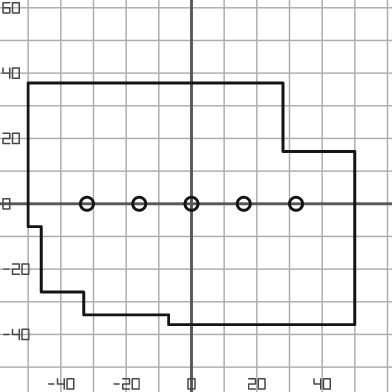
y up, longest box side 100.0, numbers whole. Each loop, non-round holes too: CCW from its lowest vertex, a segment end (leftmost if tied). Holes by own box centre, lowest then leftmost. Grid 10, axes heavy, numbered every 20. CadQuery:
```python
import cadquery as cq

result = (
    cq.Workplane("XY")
    .moveTo(-7.0, -37.0)
    .lineTo(50.0, -37.0)
    .lineTo(50.0, 16.0)
    .lineTo(28.0, 16.0)
    .lineTo(28.0, 37.0)
    .lineTo(-50.0, 37.0)
    .lineTo(-50.0, -7.0)
    .lineTo(-46.0, -7.0)
    .lineTo(-46.0, -27.0)
    .lineTo(-33.0, -27.0)
    .lineTo(-33.0, -34.0)
    .lineTo(-7.0, -34.0)
    .close()
    .moveTo(-32.0, 0.0)
    .circle(2.0)
    .moveTo(-16.0, 0.0)
    .circle(2.0)
    .moveTo(0.0, 0.0)
    .circle(2.0)
    .moveTo(16.0, 0.0)
    .circle(2.0)
    .moveTo(32.0, 0.0)
    .circle(2.0)
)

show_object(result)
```